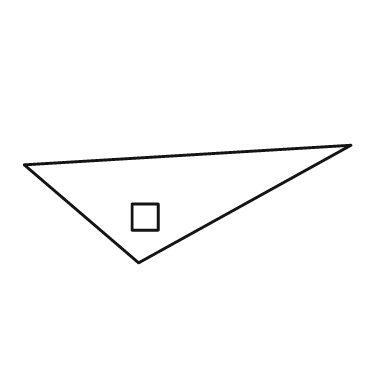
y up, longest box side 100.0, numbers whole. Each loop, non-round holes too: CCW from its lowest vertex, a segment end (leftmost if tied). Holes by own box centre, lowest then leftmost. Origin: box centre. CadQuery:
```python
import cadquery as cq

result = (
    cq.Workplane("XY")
    .moveTo(-15.0, -18.0)
    .lineTo(50.0, 18.0)
    .lineTo(-50.0, 12.0)
    .close()
    .moveTo(-17.0, -8.0)
    .lineTo(-9.0, -8.0)
    .lineTo(-9.0, 0.0)
    .lineTo(-17.0, 0.0)
    .close()
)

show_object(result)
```